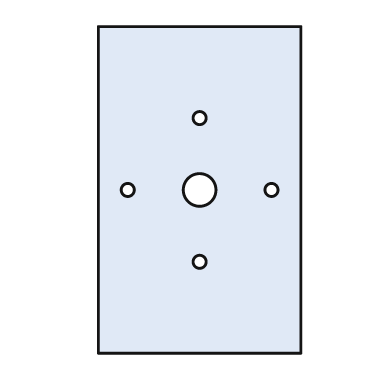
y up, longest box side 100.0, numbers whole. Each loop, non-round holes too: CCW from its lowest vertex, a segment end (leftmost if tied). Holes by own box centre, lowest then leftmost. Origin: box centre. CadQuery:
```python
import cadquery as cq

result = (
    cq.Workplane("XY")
    .moveTo(-31.0, -50.0)
    .lineTo(31.0, -50.0)
    .lineTo(31.0, 50.0)
    .lineTo(-31.0, 50.0)
    .close()
    .moveTo(0.0, -22.0)
    .circle(2.0)
    .moveTo(-22.0, 0.0)
    .circle(2.0)
    .moveTo(0.0, 0.0)
    .circle(5.0)
    .moveTo(22.0, 0.0)
    .circle(2.0)
    .moveTo(0.0, 22.0)
    .circle(2.0)
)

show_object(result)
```